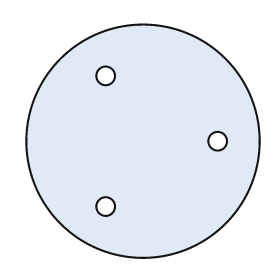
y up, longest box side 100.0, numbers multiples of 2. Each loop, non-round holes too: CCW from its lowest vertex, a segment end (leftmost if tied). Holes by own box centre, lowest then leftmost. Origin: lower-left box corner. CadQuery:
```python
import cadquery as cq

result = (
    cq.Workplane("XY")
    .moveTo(50.0, 50.0)
    .circle(50.0)
    .moveTo(34.0, 22.0)
    .circle(4.0)
    .moveTo(82.0, 50.0)
    .circle(4.0)
    .moveTo(34.0, 78.0)
    .circle(4.0)
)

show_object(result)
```